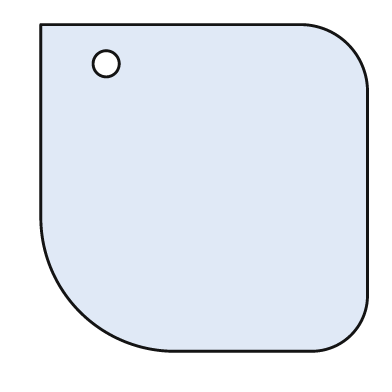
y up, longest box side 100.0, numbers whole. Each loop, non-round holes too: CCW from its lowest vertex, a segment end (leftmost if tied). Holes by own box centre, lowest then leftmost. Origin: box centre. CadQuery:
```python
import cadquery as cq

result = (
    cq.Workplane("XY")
    .moveTo(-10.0, -50.0)
    .lineTo(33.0, -50.0)
    .threePointArc((45.0, -45.0), (50.0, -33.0))
    .lineTo(50.0, 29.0)
    .threePointArc((44.0, 44.0), (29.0, 50.0))
    .lineTo(-50.0, 50.0)
    .lineTo(-50.0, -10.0)
    .threePointArc((-38.0, -38.0), (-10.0, -50.0))
    .close()
    .moveTo(-30.0, 38.0)
    .circle(4.0)
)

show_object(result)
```